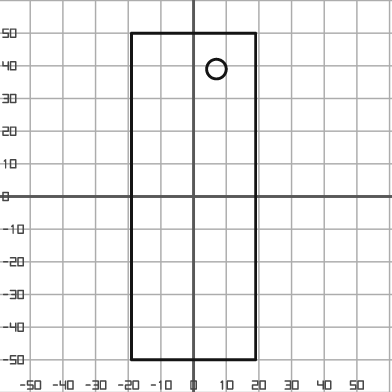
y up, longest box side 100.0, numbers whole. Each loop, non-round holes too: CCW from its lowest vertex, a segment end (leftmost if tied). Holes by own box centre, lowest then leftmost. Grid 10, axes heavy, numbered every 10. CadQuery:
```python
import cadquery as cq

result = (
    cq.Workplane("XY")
    .moveTo(-19.0, -50.0)
    .lineTo(19.0, -50.0)
    .lineTo(19.0, 50.0)
    .lineTo(-19.0, 50.0)
    .close()
    .moveTo(7.0, 39.0)
    .circle(3.0)
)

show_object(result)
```